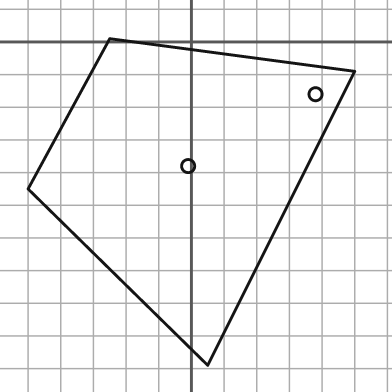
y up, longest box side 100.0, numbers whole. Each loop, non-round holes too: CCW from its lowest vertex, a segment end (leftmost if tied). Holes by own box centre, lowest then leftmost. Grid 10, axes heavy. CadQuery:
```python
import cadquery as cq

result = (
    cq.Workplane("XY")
    .moveTo(5.0, -99.0)
    .lineTo(50.0, -9.0)
    .lineTo(-25.0, 1.0)
    .lineTo(-50.0, -45.0)
    .close()
    .moveTo(-1.0, -38.0)
    .circle(2.0)
    .moveTo(38.0, -16.0)
    .circle(2.0)
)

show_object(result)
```